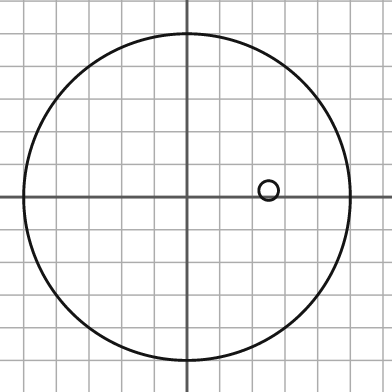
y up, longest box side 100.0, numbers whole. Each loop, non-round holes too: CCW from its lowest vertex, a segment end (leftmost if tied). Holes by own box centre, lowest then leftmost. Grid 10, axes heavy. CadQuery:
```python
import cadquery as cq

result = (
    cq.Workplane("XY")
    .moveTo(0.0, 0.0)
    .circle(50.0)
    .moveTo(25.0, 2.0)
    .circle(3.0)
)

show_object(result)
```